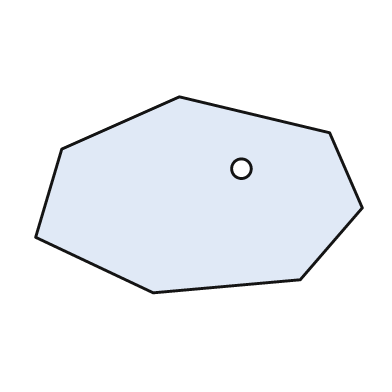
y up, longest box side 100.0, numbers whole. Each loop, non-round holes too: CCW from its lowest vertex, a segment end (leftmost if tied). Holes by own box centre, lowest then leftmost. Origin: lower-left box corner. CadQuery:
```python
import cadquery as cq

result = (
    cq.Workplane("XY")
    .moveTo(36.0, 0.0)
    .lineTo(81.0, 4.0)
    .lineTo(100.0, 26.0)
    .lineTo(90.0, 49.0)
    .lineTo(44.0, 60.0)
    .lineTo(8.0, 44.0)
    .lineTo(0.0, 17.0)
    .close()
    .moveTo(63.0, 38.0)
    .circle(3.0)
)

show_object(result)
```